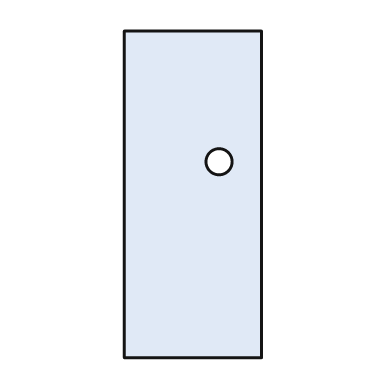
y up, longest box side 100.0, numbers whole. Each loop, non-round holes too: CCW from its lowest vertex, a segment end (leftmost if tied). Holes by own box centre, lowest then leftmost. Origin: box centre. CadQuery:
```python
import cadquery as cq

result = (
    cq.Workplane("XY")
    .moveTo(-21.0, -50.0)
    .lineTo(21.0, -50.0)
    .lineTo(21.0, 50.0)
    .lineTo(-21.0, 50.0)
    .close()
    .moveTo(8.0, 10.0)
    .circle(4.0)
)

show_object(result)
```